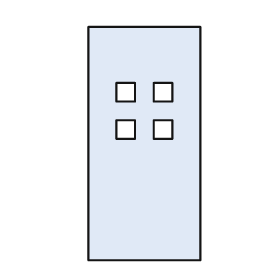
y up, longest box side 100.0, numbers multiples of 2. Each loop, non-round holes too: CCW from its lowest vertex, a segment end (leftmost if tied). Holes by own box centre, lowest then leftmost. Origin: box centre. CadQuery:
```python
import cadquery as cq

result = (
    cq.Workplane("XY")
    .moveTo(-24.0, -50.0)
    .lineTo(24.0, -50.0)
    .lineTo(24.0, 50.0)
    .lineTo(-24.0, 50.0)
    .close()
    .moveTo(-12.0, 2.0)
    .lineTo(-4.0, 2.0)
    .lineTo(-4.0, 10.0)
    .lineTo(-12.0, 10.0)
    .close()
    .moveTo(4.0, 2.0)
    .lineTo(12.0, 2.0)
    .lineTo(12.0, 10.0)
    .lineTo(4.0, 10.0)
    .close()
    .moveTo(-12.0, 18.0)
    .lineTo(-4.0, 18.0)
    .lineTo(-4.0, 26.0)
    .lineTo(-12.0, 26.0)
    .close()
    .moveTo(4.0, 18.0)
    .lineTo(12.0, 18.0)
    .lineTo(12.0, 26.0)
    .lineTo(4.0, 26.0)
    .close()
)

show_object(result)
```